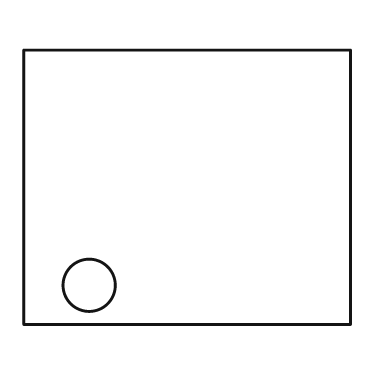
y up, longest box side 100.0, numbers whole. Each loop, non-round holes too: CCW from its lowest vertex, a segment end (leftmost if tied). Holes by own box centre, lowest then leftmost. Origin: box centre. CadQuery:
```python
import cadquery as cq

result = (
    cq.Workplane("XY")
    .moveTo(-50.0, -42.0)
    .lineTo(50.0, -42.0)
    .lineTo(50.0, 42.0)
    .lineTo(-50.0, 42.0)
    .close()
    .moveTo(-30.0, -30.0)
    .circle(8.0)
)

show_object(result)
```